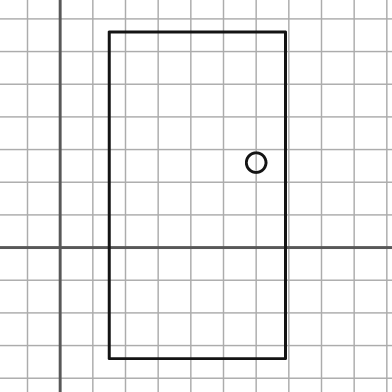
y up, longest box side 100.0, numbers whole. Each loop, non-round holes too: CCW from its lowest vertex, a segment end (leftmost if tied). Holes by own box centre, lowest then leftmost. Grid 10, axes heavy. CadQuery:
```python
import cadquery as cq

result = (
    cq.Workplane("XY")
    .moveTo(15.0, -34.0)
    .lineTo(69.0, -34.0)
    .lineTo(69.0, 66.0)
    .lineTo(15.0, 66.0)
    .close()
    .moveTo(60.0, 26.0)
    .circle(3.0)
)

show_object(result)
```